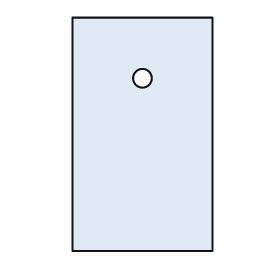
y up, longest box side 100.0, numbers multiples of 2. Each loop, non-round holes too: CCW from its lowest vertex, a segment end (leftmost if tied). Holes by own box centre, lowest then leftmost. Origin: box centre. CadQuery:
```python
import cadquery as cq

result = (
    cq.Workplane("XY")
    .moveTo(-30.0, -50.0)
    .lineTo(30.0, -50.0)
    .lineTo(30.0, 50.0)
    .lineTo(-30.0, 50.0)
    .close()
    .moveTo(0.0, 24.0)
    .circle(4.0)
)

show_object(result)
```